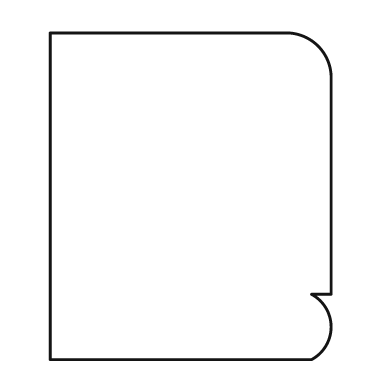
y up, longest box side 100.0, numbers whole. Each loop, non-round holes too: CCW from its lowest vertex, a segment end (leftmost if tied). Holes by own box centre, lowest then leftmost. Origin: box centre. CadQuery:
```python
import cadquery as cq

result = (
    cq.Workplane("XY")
    .moveTo(-43.0, -50.0)
    .lineTo(37.0, -50.0)
    .threePointArc((43.0, -40.0), (37.0, -30.0))
    .lineTo(43.0, -30.0)
    .lineTo(43.0, 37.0)
    .threePointArc((39.0, 46.0), (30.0, 50.0))
    .lineTo(-43.0, 50.0)
    .close()
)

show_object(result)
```